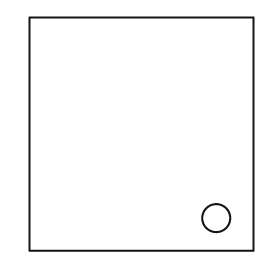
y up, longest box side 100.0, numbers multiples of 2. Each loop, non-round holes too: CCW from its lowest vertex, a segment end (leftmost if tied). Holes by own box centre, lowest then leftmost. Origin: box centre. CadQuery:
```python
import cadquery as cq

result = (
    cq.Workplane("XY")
    .moveTo(-48.0, -50.0)
    .lineTo(48.0, -50.0)
    .lineTo(48.0, 50.0)
    .lineTo(-48.0, 50.0)
    .close()
    .moveTo(32.0, -36.0)
    .circle(6.0)
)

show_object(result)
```